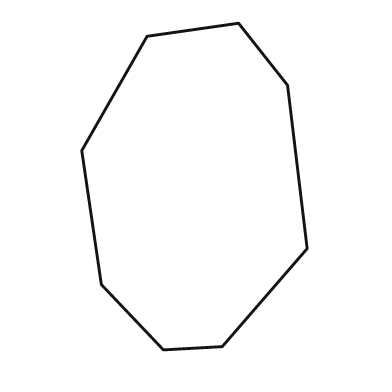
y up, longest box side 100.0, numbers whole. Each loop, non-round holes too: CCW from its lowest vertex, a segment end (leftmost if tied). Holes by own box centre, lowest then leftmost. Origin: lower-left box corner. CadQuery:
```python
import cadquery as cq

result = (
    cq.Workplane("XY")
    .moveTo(25.0, 0.0)
    .lineTo(43.0, 1.0)
    .lineTo(69.0, 31.0)
    .lineTo(63.0, 81.0)
    .lineTo(48.0, 100.0)
    .lineTo(20.0, 96.0)
    .lineTo(0.0, 61.0)
    .lineTo(6.0, 20.0)
    .close()
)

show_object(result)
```